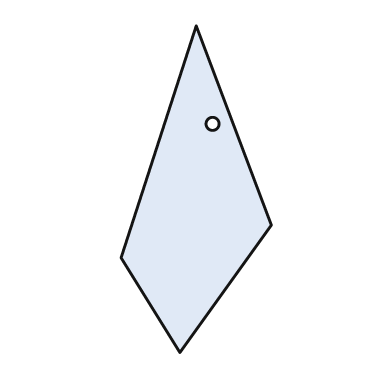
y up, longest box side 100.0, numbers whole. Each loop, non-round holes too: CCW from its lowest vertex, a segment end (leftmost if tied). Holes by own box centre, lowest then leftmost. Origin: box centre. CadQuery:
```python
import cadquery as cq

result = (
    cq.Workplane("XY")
    .moveTo(-5.0, -50.0)
    .lineTo(23.0, -11.0)
    .lineTo(0.0, 50.0)
    .lineTo(-23.0, -21.0)
    .close()
    .moveTo(5.0, 20.0)
    .circle(2.0)
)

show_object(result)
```